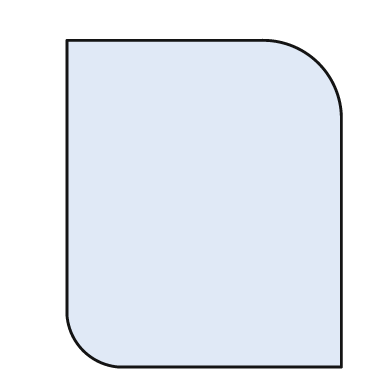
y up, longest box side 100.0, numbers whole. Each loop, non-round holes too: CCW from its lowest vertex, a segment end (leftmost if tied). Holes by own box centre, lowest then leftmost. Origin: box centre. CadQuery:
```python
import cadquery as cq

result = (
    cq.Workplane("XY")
    .moveTo(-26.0, -50.0)
    .lineTo(42.0, -50.0)
    .lineTo(42.0, 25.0)
    .threePointArc((35.0, 43.0), (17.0, 50.0))
    .lineTo(-42.0, 50.0)
    .lineTo(-42.0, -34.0)
    .threePointArc((-37.0, -45.0), (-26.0, -50.0))
    .close()
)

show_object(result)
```